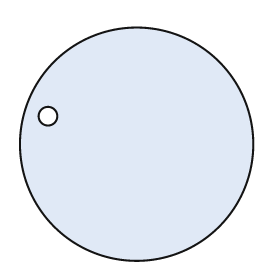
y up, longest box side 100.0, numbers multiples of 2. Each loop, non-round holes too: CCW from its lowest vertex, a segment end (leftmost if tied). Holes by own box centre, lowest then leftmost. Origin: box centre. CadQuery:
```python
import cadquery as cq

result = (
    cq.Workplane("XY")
    .moveTo(0.0, 0.0)
    .circle(50.0)
    .moveTo(-38.0, 12.0)
    .circle(4.0)
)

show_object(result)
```